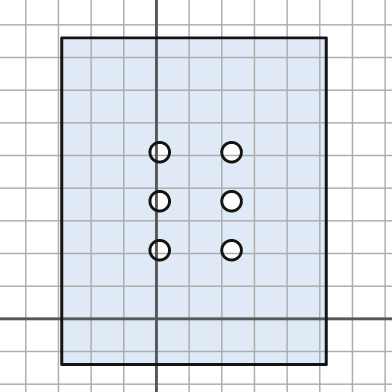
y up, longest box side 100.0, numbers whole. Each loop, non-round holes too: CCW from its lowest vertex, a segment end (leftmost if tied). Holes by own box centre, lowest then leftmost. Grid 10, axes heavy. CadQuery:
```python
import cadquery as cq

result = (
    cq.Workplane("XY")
    .moveTo(-29.0, -14.0)
    .lineTo(52.0, -14.0)
    .lineTo(52.0, 86.0)
    .lineTo(-29.0, 86.0)
    .close()
    .moveTo(1.0, 21.0)
    .circle(3.0)
    .moveTo(23.0, 21.0)
    .circle(3.0)
    .moveTo(1.0, 36.0)
    .circle(3.0)
    .moveTo(23.0, 36.0)
    .circle(3.0)
    .moveTo(1.0, 51.0)
    .circle(3.0)
    .moveTo(23.0, 51.0)
    .circle(3.0)
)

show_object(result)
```